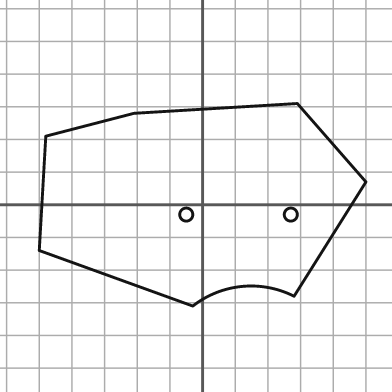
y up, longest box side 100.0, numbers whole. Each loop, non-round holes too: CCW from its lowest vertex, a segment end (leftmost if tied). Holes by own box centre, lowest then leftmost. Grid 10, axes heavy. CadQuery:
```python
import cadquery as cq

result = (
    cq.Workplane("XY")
    .moveTo(-3.0, -31.0)
    .threePointArc((12.0, -25.0), (28.0, -28.0))
    .lineTo(50.0, 7.0)
    .lineTo(29.0, 31.0)
    .lineTo(-21.0, 28.0)
    .lineTo(-48.0, 21.0)
    .lineTo(-50.0, -14.0)
    .close()
    .moveTo(-5.0, -3.0)
    .circle(2.0)
    .moveTo(27.0, -3.0)
    .circle(2.0)
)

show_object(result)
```